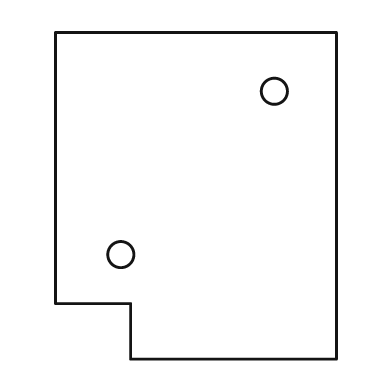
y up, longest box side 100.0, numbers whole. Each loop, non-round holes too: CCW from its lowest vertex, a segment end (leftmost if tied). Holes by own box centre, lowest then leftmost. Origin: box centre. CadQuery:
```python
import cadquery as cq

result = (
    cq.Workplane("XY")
    .moveTo(-20.0, -50.0)
    .lineTo(43.0, -50.0)
    .lineTo(43.0, 50.0)
    .lineTo(-43.0, 50.0)
    .lineTo(-43.0, -33.0)
    .lineTo(-20.0, -33.0)
    .close()
    .moveTo(-23.0, -18.0)
    .circle(4.0)
    .moveTo(24.0, 32.0)
    .circle(4.0)
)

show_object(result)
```